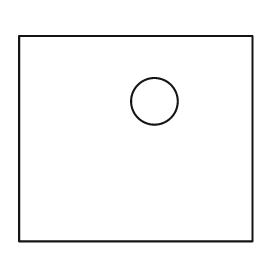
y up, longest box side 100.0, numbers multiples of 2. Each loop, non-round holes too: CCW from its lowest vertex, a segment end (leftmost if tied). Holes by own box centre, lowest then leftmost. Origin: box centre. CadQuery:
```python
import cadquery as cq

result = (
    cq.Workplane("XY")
    .moveTo(-50.0, -44.0)
    .lineTo(50.0, -44.0)
    .lineTo(50.0, 44.0)
    .lineTo(-50.0, 44.0)
    .close()
    .moveTo(8.0, 16.0)
    .circle(10.0)
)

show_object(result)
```